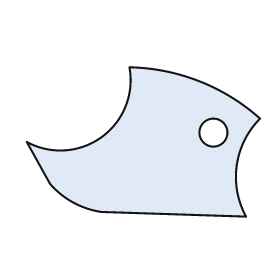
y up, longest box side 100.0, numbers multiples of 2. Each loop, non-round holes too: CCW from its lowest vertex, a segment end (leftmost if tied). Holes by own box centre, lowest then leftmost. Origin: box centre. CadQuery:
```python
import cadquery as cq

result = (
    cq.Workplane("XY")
    .moveTo(44.0, -32.0)
    .threePointArc((40.0, -10.0), (50.0, 10.0))
    .threePointArc((24.0, 26.0), (-6.0, 32.0))
    .threePointArc((-18.0, 2.0), (-50.0, 0.0))
    .lineTo(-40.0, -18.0)
    .threePointArc((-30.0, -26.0), (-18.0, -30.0))
    .close()
    .moveTo(30.0, 4.0)
    .circle(6.0)
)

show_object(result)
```